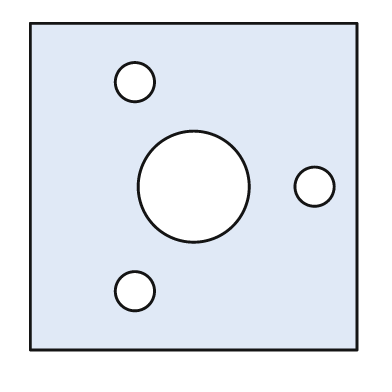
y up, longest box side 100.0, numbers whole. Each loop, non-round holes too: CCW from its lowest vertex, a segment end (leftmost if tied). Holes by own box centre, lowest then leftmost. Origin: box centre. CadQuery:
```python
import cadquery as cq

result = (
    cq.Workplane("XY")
    .moveTo(-50.0, -50.0)
    .lineTo(50.0, -50.0)
    .lineTo(50.0, 50.0)
    .lineTo(-50.0, 50.0)
    .close()
    .moveTo(-18.0, -32.0)
    .circle(6.0)
    .moveTo(0.0, 0.0)
    .circle(17.0)
    .moveTo(37.0, 0.0)
    .circle(6.0)
    .moveTo(-18.0, 32.0)
    .circle(6.0)
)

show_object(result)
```